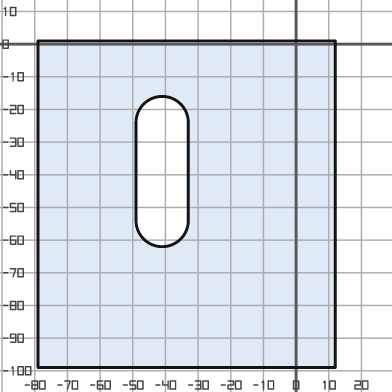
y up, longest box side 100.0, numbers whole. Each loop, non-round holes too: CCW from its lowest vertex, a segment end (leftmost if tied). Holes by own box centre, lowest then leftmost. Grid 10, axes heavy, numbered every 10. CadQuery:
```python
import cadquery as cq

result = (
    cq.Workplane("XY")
    .moveTo(-79.0, -99.0)
    .lineTo(12.0, -99.0)
    .lineTo(12.0, 1.0)
    .lineTo(-79.0, 1.0)
    .close()
    .moveTo(-49.0, -54.0)
    .threePointArc((-41.0, -62.0), (-33.0, -54.0))
    .lineTo(-33.0, -24.0)
    .threePointArc((-41.0, -16.0), (-49.0, -24.0))
    .close()
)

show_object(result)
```